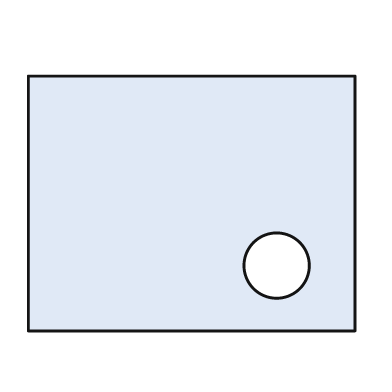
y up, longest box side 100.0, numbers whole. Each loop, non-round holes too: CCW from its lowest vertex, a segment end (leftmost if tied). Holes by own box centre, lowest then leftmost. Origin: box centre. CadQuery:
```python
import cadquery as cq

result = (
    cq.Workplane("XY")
    .moveTo(-50.0, -39.0)
    .lineTo(50.0, -39.0)
    .lineTo(50.0, 39.0)
    .lineTo(-50.0, 39.0)
    .close()
    .moveTo(26.0, -19.0)
    .circle(10.0)
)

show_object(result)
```